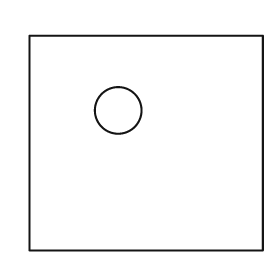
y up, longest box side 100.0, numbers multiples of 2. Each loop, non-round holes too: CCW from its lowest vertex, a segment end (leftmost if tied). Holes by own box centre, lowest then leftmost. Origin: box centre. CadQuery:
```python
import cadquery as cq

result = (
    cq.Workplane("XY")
    .moveTo(-50.0, -46.0)
    .lineTo(50.0, -46.0)
    .lineTo(50.0, 46.0)
    .lineTo(-50.0, 46.0)
    .close()
    .moveTo(-12.0, 14.0)
    .circle(10.0)
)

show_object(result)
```